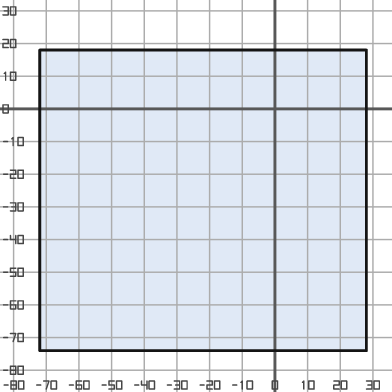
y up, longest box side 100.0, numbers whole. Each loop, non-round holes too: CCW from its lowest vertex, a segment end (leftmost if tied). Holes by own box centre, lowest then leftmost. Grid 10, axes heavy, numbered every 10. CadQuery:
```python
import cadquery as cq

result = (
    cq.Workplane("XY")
    .moveTo(-72.0, -74.0)
    .lineTo(28.0, -74.0)
    .lineTo(28.0, 18.0)
    .lineTo(-72.0, 18.0)
    .close()
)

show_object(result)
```